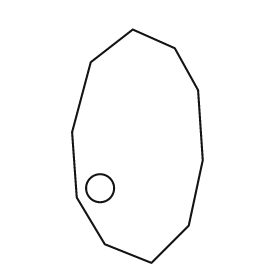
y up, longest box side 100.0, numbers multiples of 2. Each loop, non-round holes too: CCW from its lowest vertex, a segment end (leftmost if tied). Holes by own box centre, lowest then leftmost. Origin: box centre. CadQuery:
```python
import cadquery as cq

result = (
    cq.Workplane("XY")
    .moveTo(6.0, -50.0)
    .lineTo(22.0, -34.0)
    .lineTo(28.0, -6.0)
    .lineTo(26.0, 24.0)
    .lineTo(16.0, 42.0)
    .lineTo(-2.0, 50.0)
    .lineTo(-20.0, 36.0)
    .lineTo(-28.0, 6.0)
    .lineTo(-26.0, -22.0)
    .lineTo(-14.0, -42.0)
    .close()
    .moveTo(-16.0, -18.0)
    .circle(6.0)
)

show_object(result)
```